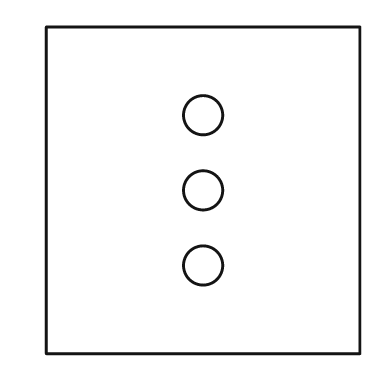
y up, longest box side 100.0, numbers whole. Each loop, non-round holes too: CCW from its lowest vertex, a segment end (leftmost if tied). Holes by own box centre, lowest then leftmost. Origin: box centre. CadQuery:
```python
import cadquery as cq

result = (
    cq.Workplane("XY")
    .moveTo(-48.0, -50.0)
    .lineTo(48.0, -50.0)
    .lineTo(48.0, 50.0)
    .lineTo(-48.0, 50.0)
    .close()
    .moveTo(0.0, -23.0)
    .circle(6.0)
    .moveTo(0.0, 0.0)
    .circle(6.0)
    .moveTo(0.0, 23.0)
    .circle(6.0)
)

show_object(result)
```